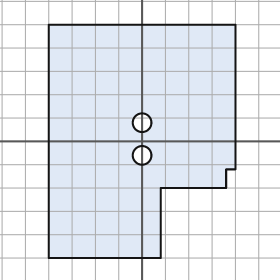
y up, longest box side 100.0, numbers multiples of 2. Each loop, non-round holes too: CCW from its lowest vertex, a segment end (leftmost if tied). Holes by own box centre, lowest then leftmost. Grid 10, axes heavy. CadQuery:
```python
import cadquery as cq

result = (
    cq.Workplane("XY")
    .moveTo(-40.0, -50.0)
    .lineTo(8.0, -50.0)
    .lineTo(8.0, -20.0)
    .lineTo(36.0, -20.0)
    .lineTo(36.0, -12.0)
    .lineTo(40.0, -12.0)
    .lineTo(40.0, 50.0)
    .lineTo(-40.0, 50.0)
    .close()
    .moveTo(0.0, -6.0)
    .circle(4.0)
    .moveTo(0.0, 8.0)
    .circle(4.0)
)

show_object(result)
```